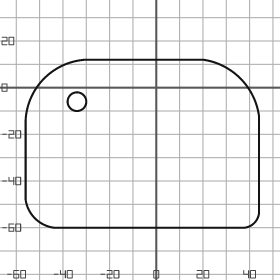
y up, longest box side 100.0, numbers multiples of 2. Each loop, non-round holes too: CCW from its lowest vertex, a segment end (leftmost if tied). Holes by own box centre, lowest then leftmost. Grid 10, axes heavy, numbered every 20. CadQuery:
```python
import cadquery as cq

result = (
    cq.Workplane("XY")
    .moveTo(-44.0, -60.0)
    .lineTo(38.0, -60.0)
    .threePointArc((42.0, -58.0), (44.0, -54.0))
    .lineTo(44.0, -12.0)
    .threePointArc((36.0, 4.0), (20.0, 12.0))
    .lineTo(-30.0, 12.0)
    .threePointArc((-48.0, 4.0), (-56.0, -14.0))
    .lineTo(-56.0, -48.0)
    .threePointArc((-52.0, -56.0), (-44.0, -60.0))
    .close()
    .moveTo(-34.0, -6.0)
    .circle(4.0)
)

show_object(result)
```